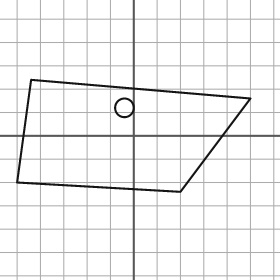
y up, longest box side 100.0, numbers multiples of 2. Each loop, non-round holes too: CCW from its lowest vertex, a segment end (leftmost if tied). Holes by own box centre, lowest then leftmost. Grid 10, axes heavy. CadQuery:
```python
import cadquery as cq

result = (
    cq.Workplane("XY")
    .moveTo(20.0, -24.0)
    .lineTo(50.0, 16.0)
    .lineTo(-44.0, 24.0)
    .lineTo(-50.0, -20.0)
    .close()
    .moveTo(-4.0, 12.0)
    .circle(4.0)
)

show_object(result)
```